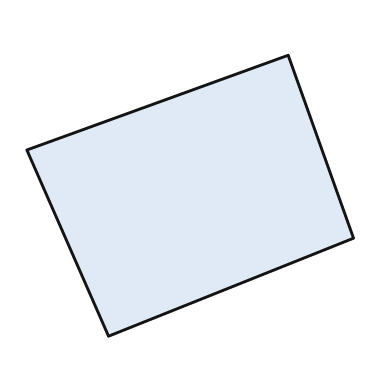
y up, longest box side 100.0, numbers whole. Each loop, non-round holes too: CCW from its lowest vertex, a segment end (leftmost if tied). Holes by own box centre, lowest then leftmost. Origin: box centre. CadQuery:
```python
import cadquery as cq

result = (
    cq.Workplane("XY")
    .moveTo(-25.0, -43.0)
    .lineTo(50.0, -13.0)
    .lineTo(30.0, 43.0)
    .lineTo(-50.0, 14.0)
    .close()
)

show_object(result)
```